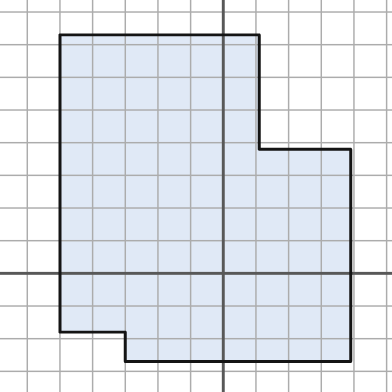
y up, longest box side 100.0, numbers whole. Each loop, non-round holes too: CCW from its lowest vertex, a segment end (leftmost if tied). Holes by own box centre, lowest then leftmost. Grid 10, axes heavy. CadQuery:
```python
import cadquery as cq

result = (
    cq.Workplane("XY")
    .moveTo(-30.0, -27.0)
    .lineTo(39.0, -27.0)
    .lineTo(39.0, 38.0)
    .lineTo(11.0, 38.0)
    .lineTo(11.0, 73.0)
    .lineTo(-50.0, 73.0)
    .lineTo(-50.0, -18.0)
    .lineTo(-30.0, -18.0)
    .close()
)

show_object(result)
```